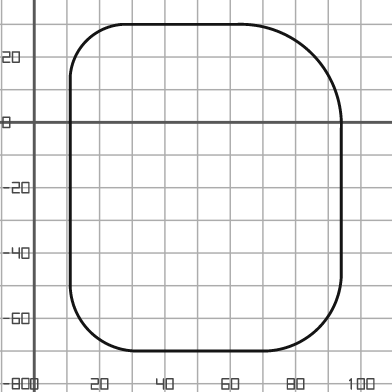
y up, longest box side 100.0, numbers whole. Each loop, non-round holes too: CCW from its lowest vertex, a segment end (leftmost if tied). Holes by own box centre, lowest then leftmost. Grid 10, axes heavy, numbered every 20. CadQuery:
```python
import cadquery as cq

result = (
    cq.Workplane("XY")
    .moveTo(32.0, -70.0)
    .lineTo(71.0, -70.0)
    .threePointArc((87.0, -63.0), (94.0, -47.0))
    .lineTo(94.0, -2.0)
    .threePointArc((85.0, 21.0), (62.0, 30.0))
    .lineTo(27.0, 30.0)
    .threePointArc((16.0, 25.0), (11.0, 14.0))
    .lineTo(11.0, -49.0)
    .threePointArc((17.0, -64.0), (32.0, -70.0))
    .close()
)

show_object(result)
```